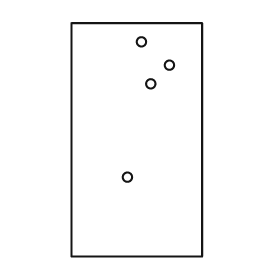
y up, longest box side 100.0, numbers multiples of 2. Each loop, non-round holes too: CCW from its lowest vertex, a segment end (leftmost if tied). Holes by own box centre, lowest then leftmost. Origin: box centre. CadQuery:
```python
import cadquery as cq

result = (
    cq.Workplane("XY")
    .moveTo(-28.0, -50.0)
    .lineTo(28.0, -50.0)
    .lineTo(28.0, 50.0)
    .lineTo(-28.0, 50.0)
    .close()
    .moveTo(-4.0, -16.0)
    .circle(2.0)
    .moveTo(6.0, 24.0)
    .circle(2.0)
    .moveTo(14.0, 32.0)
    .circle(2.0)
    .moveTo(2.0, 42.0)
    .circle(2.0)
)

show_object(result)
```